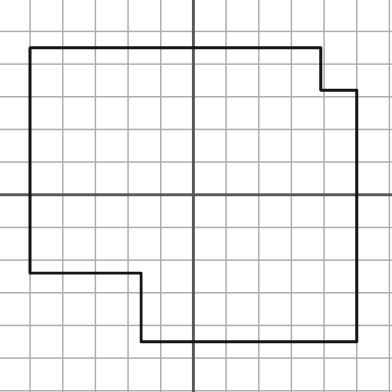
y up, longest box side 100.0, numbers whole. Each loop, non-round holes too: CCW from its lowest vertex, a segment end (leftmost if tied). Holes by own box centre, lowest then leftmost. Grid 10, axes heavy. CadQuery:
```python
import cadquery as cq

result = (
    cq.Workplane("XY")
    .moveTo(-16.0, -45.0)
    .lineTo(50.0, -45.0)
    .lineTo(50.0, 32.0)
    .lineTo(39.0, 32.0)
    .lineTo(39.0, 45.0)
    .lineTo(-50.0, 45.0)
    .lineTo(-50.0, -24.0)
    .lineTo(-16.0, -24.0)
    .close()
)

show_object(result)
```